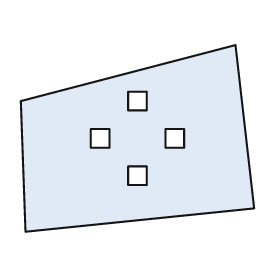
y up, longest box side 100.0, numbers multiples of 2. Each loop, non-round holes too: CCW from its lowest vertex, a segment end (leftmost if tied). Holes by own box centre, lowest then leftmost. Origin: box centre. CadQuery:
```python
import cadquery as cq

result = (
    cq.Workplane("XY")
    .moveTo(-48.0, -40.0)
    .lineTo(50.0, -30.0)
    .lineTo(42.0, 40.0)
    .lineTo(-50.0, 16.0)
    .close()
    .moveTo(-4.0, -20.0)
    .lineTo(4.0, -20.0)
    .lineTo(4.0, -12.0)
    .lineTo(-4.0, -12.0)
    .close()
    .moveTo(-20.0, -4.0)
    .lineTo(-12.0, -4.0)
    .lineTo(-12.0, 4.0)
    .lineTo(-20.0, 4.0)
    .close()
    .moveTo(12.0, -4.0)
    .lineTo(20.0, -4.0)
    .lineTo(20.0, 4.0)
    .lineTo(12.0, 4.0)
    .close()
    .moveTo(-4.0, 12.0)
    .lineTo(4.0, 12.0)
    .lineTo(4.0, 20.0)
    .lineTo(-4.0, 20.0)
    .close()
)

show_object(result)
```